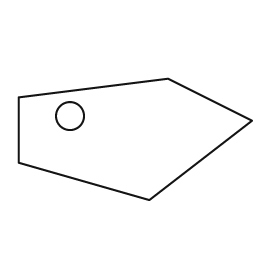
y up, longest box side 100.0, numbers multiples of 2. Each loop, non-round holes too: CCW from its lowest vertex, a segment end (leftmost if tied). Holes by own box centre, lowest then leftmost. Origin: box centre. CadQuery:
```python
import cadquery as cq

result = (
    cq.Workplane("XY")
    .moveTo(6.0, -26.0)
    .lineTo(50.0, 8.0)
    .lineTo(14.0, 26.0)
    .lineTo(-50.0, 18.0)
    .lineTo(-50.0, -10.0)
    .close()
    .moveTo(-28.0, 10.0)
    .circle(6.0)
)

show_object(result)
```